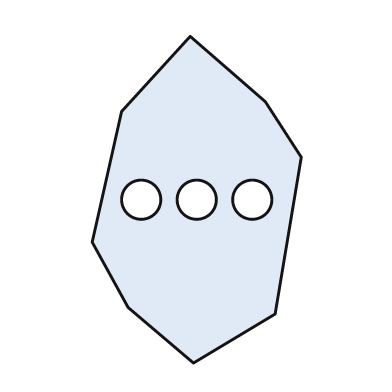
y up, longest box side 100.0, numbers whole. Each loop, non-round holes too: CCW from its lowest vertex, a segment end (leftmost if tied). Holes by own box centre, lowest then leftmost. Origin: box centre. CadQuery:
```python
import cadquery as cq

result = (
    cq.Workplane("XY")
    .moveTo(-1.0, -50.0)
    .lineTo(24.0, -35.0)
    .lineTo(32.0, 13.0)
    .lineTo(21.0, 30.0)
    .lineTo(-2.0, 50.0)
    .lineTo(-23.0, 27.0)
    .lineTo(-32.0, -13.0)
    .lineTo(-21.0, -33.0)
    .close()
    .moveTo(-17.0, 0.0)
    .circle(6.0)
    .moveTo(0.0, 0.0)
    .circle(6.0)
    .moveTo(17.0, 0.0)
    .circle(6.0)
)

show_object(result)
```